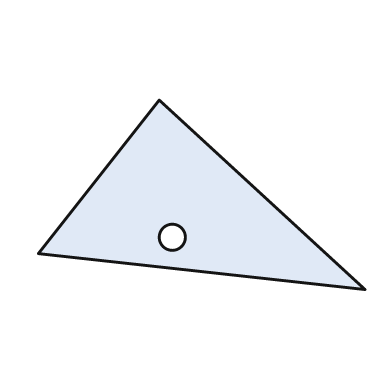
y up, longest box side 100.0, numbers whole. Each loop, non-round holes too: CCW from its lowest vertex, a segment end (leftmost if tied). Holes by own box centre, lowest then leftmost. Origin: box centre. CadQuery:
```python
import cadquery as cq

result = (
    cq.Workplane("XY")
    .moveTo(50.0, -29.0)
    .lineTo(-13.0, 29.0)
    .lineTo(-50.0, -18.0)
    .close()
    .moveTo(-9.0, -13.0)
    .circle(4.0)
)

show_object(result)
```